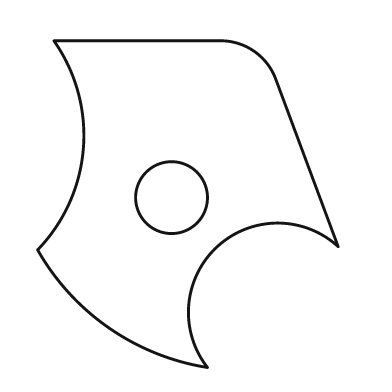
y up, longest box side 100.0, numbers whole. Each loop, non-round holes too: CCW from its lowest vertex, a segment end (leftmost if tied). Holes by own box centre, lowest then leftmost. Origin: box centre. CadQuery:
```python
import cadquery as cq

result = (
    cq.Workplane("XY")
    .moveTo(6.0, -50.0)
    .threePointArc((9.0, -13.0), (46.0, -13.0))
    .lineTo(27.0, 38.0)
    .threePointArc((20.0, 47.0), (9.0, 50.0))
    .lineTo(-41.0, 50.0)
    .threePointArc((-32.0, 17.0), (-46.0, -14.0))
    .threePointArc((-24.0, -38.0), (6.0, -50.0))
    .close()
    .moveTo(-5.0, 2.0)
    .circle(11.0)
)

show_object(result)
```